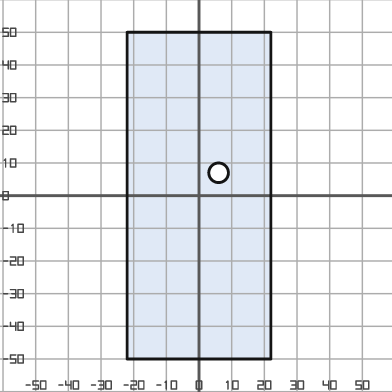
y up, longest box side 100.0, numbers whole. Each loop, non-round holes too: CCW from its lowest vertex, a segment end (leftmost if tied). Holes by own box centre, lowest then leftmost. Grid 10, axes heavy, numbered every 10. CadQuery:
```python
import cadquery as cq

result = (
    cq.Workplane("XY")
    .moveTo(-22.0, -50.0)
    .lineTo(22.0, -50.0)
    .lineTo(22.0, 50.0)
    .lineTo(-22.0, 50.0)
    .close()
    .moveTo(6.0, 7.0)
    .circle(3.0)
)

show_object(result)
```